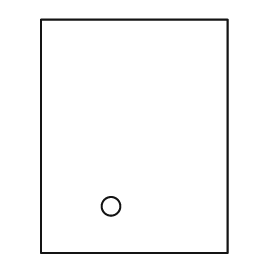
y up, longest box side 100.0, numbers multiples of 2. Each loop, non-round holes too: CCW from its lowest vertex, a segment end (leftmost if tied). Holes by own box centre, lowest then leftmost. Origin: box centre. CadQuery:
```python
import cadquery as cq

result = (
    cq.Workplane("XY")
    .moveTo(-40.0, -50.0)
    .lineTo(40.0, -50.0)
    .lineTo(40.0, 50.0)
    .lineTo(-40.0, 50.0)
    .close()
    .moveTo(-10.0, -30.0)
    .circle(4.0)
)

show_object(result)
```